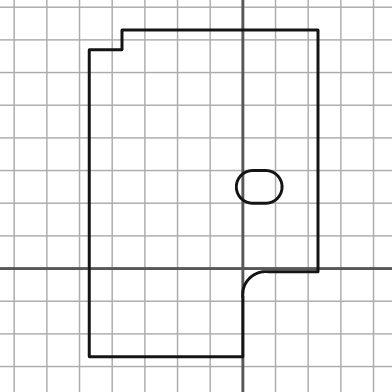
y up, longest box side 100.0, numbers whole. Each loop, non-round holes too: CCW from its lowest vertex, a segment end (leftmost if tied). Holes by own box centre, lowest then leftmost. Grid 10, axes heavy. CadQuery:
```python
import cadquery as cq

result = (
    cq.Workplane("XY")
    .moveTo(-47.0, -27.0)
    .lineTo(0.0, -27.0)
    .lineTo(0.0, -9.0)
    .threePointArc((2.0, -3.0), (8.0, -1.0))
    .lineTo(23.0, -1.0)
    .lineTo(23.0, 73.0)
    .lineTo(-37.0, 73.0)
    .lineTo(-37.0, 67.0)
    .lineTo(-47.0, 67.0)
    .close()
    .moveTo(3.0, 20.0)
    .lineTo(7.0, 20.0)
    .threePointArc((12.0, 25.0), (7.0, 30.0))
    .lineTo(3.0, 30.0)
    .threePointArc((-2.0, 25.0), (3.0, 20.0))
    .close()
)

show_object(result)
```